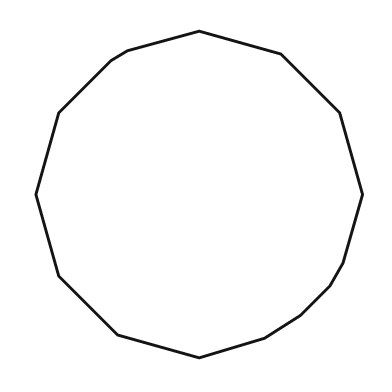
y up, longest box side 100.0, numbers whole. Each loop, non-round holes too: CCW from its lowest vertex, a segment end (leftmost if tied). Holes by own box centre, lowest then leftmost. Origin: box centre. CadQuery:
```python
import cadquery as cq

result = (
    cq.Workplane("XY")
    .moveTo(0.0, -50.0)
    .lineTo(20.0, -44.0)
    .lineTo(31.0, -37.0)
    .lineTo(40.0, -28.0)
    .lineTo(44.0, -21.0)
    .lineTo(50.0, 0.0)
    .lineTo(43.0, 25.0)
    .lineTo(25.0, 43.0)
    .lineTo(0.0, 50.0)
    .lineTo(-22.0, 44.0)
    .lineTo(-27.0, 41.0)
    .lineTo(-43.0, 25.0)
    .lineTo(-50.0, 0.0)
    .lineTo(-43.0, -25.0)
    .lineTo(-25.0, -43.0)
    .close()
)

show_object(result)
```